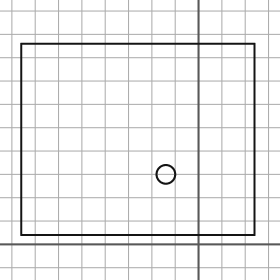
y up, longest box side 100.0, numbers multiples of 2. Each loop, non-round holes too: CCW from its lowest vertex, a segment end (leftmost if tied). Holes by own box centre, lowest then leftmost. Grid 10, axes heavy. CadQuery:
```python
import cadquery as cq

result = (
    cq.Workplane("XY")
    .moveTo(-76.0, 4.0)
    .lineTo(24.0, 4.0)
    .lineTo(24.0, 86.0)
    .lineTo(-76.0, 86.0)
    .close()
    .moveTo(-14.0, 30.0)
    .circle(4.0)
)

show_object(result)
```